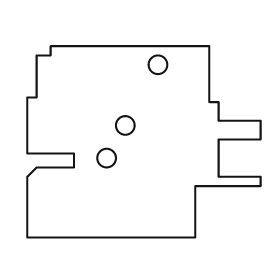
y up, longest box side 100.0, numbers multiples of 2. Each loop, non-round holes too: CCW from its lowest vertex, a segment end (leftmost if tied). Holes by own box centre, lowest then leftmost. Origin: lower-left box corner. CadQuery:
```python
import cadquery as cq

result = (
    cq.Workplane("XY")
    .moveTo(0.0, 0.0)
    .lineTo(72.0, 0.0)
    .lineTo(72.0, 22.0)
    .lineTo(100.0, 22.0)
    .lineTo(100.0, 26.0)
    .lineTo(82.0, 26.0)
    .lineTo(82.0, 42.0)
    .lineTo(100.0, 42.0)
    .lineTo(100.0, 50.0)
    .lineTo(82.0, 50.0)
    .lineTo(82.0, 58.0)
    .lineTo(78.0, 58.0)
    .lineTo(78.0, 82.0)
    .lineTo(10.0, 82.0)
    .lineTo(10.0, 78.0)
    .lineTo(4.0, 78.0)
    .lineTo(4.0, 60.0)
    .lineTo(0.0, 60.0)
    .lineTo(0.0, 36.0)
    .lineTo(20.0, 36.0)
    .lineTo(20.0, 30.0)
    .lineTo(4.0, 30.0)
    .lineTo(0.0, 26.0)
    .close()
    .moveTo(34.0, 34.0)
    .circle(4.0)
    .moveTo(42.0, 48.0)
    .circle(4.0)
    .moveTo(56.0, 74.0)
    .circle(4.0)
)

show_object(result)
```